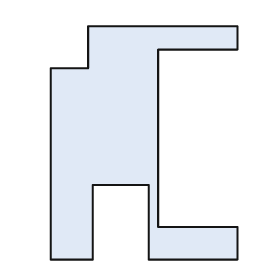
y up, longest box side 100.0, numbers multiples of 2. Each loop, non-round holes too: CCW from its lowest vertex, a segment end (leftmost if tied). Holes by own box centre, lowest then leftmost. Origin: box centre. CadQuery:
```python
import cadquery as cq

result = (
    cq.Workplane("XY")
    .moveTo(-40.0, -50.0)
    .lineTo(-22.0, -50.0)
    .lineTo(-22.0, -18.0)
    .lineTo(2.0, -18.0)
    .lineTo(2.0, -50.0)
    .lineTo(40.0, -50.0)
    .lineTo(40.0, -36.0)
    .lineTo(6.0, -36.0)
    .lineTo(6.0, 40.0)
    .lineTo(40.0, 40.0)
    .lineTo(40.0, 50.0)
    .lineTo(-24.0, 50.0)
    .lineTo(-24.0, 32.0)
    .lineTo(-40.0, 32.0)
    .close()
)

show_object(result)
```